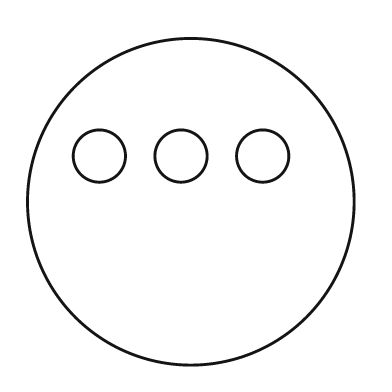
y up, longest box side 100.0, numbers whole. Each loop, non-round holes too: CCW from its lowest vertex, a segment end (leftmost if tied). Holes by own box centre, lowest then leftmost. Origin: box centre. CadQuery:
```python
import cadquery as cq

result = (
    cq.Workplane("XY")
    .moveTo(0.0, 0.0)
    .circle(50.0)
    .moveTo(-28.0, 14.0)
    .circle(8.0)
    .moveTo(-3.0, 14.0)
    .circle(8.0)
    .moveTo(22.0, 14.0)
    .circle(8.0)
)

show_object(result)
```